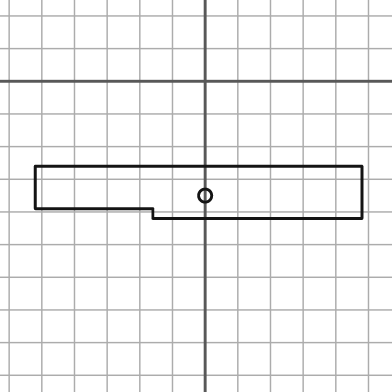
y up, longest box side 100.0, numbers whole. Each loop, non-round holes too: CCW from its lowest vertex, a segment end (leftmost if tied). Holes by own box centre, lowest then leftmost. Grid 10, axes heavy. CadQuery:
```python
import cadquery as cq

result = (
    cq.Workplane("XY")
    .moveTo(-16.0, -42.0)
    .lineTo(48.0, -42.0)
    .lineTo(48.0, -26.0)
    .lineTo(-52.0, -26.0)
    .lineTo(-52.0, -39.0)
    .lineTo(-16.0, -39.0)
    .close()
    .moveTo(0.0, -35.0)
    .circle(2.0)
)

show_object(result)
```